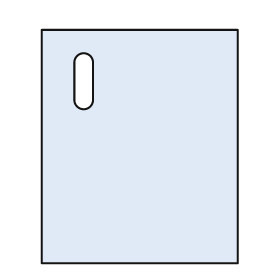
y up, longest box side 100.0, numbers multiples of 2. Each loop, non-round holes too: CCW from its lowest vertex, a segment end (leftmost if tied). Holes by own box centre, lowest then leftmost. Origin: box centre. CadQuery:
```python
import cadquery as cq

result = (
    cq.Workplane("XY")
    .moveTo(-42.0, -50.0)
    .lineTo(42.0, -50.0)
    .lineTo(42.0, 50.0)
    .lineTo(-42.0, 50.0)
    .close()
    .moveTo(-28.0, 20.0)
    .threePointArc((-24.0, 16.0), (-20.0, 20.0))
    .lineTo(-20.0, 36.0)
    .threePointArc((-24.0, 40.0), (-28.0, 36.0))
    .close()
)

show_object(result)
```